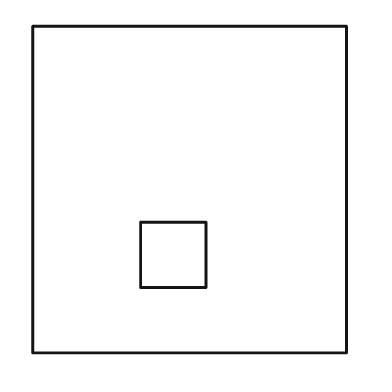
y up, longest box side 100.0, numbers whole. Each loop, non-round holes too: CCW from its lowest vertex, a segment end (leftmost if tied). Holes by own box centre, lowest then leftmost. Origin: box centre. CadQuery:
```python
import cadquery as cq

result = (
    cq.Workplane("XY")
    .moveTo(-48.0, -50.0)
    .lineTo(48.0, -50.0)
    .lineTo(48.0, 50.0)
    .lineTo(-48.0, 50.0)
    .close()
    .moveTo(-15.0, -30.0)
    .lineTo(5.0, -30.0)
    .lineTo(5.0, -10.0)
    .lineTo(-15.0, -10.0)
    .close()
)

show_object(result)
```